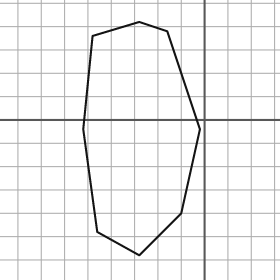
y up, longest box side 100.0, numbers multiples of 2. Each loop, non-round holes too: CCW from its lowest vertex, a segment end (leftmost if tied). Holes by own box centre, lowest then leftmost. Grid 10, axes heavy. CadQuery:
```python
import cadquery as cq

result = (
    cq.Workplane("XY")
    .moveTo(-28.0, -58.0)
    .lineTo(-10.0, -40.0)
    .lineTo(-2.0, -4.0)
    .lineTo(-16.0, 38.0)
    .lineTo(-28.0, 42.0)
    .lineTo(-48.0, 36.0)
    .lineTo(-52.0, -4.0)
    .lineTo(-46.0, -48.0)
    .close()
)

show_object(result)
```